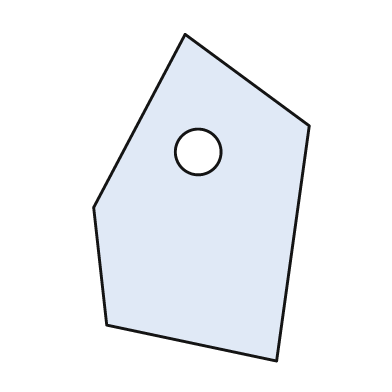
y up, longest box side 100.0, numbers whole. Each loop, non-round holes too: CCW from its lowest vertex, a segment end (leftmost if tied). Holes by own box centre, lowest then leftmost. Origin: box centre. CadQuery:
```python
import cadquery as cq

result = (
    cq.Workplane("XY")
    .moveTo(23.0, -50.0)
    .lineTo(33.0, 22.0)
    .lineTo(-5.0, 50.0)
    .lineTo(-33.0, -3.0)
    .lineTo(-29.0, -39.0)
    .close()
    .moveTo(-1.0, 14.0)
    .circle(7.0)
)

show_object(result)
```